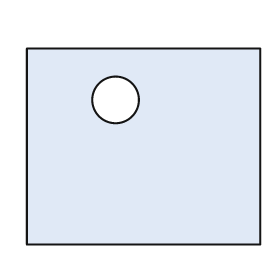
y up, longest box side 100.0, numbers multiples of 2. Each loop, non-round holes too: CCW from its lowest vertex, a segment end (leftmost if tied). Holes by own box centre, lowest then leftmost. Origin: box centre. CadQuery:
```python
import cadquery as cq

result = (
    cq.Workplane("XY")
    .moveTo(-50.0, -42.0)
    .lineTo(50.0, -42.0)
    .lineTo(50.0, 42.0)
    .lineTo(-50.0, 42.0)
    .close()
    .moveTo(-12.0, 20.0)
    .circle(10.0)
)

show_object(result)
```